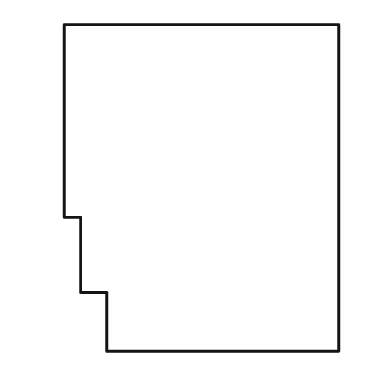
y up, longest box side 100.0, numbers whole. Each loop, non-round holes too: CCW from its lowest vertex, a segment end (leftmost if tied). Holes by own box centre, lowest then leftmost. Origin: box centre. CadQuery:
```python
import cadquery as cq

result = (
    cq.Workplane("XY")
    .moveTo(-29.0, -50.0)
    .lineTo(42.0, -50.0)
    .lineTo(42.0, 50.0)
    .lineTo(-42.0, 50.0)
    .lineTo(-42.0, -9.0)
    .lineTo(-37.0, -9.0)
    .lineTo(-37.0, -32.0)
    .lineTo(-29.0, -32.0)
    .close()
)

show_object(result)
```